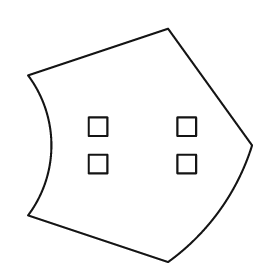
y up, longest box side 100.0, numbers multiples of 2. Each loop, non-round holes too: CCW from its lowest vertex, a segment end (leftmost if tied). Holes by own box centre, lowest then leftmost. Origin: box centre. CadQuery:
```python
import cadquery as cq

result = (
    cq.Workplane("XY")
    .moveTo(12.0, -50.0)
    .threePointArc((34.0, -28.0), (48.0, 0.0))
    .lineTo(12.0, 50.0)
    .lineTo(-48.0, 30.0)
    .threePointArc((-38.0, 0.0), (-48.0, -30.0))
    .close()
    .moveTo(-22.0, -12.0)
    .lineTo(-14.0, -12.0)
    .lineTo(-14.0, -4.0)
    .lineTo(-22.0, -4.0)
    .close()
    .moveTo(16.0, -12.0)
    .lineTo(24.0, -12.0)
    .lineTo(24.0, -4.0)
    .lineTo(16.0, -4.0)
    .close()
    .moveTo(-22.0, 4.0)
    .lineTo(-14.0, 4.0)
    .lineTo(-14.0, 12.0)
    .lineTo(-22.0, 12.0)
    .close()
    .moveTo(16.0, 4.0)
    .lineTo(24.0, 4.0)
    .lineTo(24.0, 12.0)
    .lineTo(16.0, 12.0)
    .close()
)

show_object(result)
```